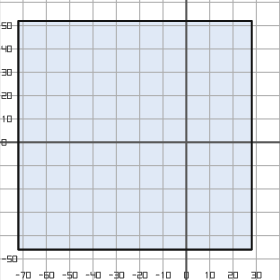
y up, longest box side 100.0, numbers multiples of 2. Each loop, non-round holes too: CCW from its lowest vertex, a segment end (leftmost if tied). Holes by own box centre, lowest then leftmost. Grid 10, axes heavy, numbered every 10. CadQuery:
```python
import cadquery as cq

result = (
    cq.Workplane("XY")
    .moveTo(-72.0, -46.0)
    .lineTo(28.0, -46.0)
    .lineTo(28.0, 52.0)
    .lineTo(-72.0, 52.0)
    .close()
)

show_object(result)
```